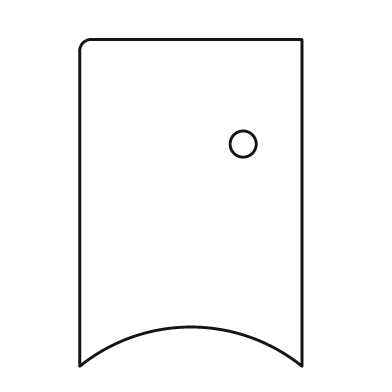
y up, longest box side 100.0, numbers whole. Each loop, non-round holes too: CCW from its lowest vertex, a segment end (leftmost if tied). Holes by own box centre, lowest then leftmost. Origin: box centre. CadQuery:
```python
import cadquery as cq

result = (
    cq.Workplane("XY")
    .moveTo(-34.0, -50.0)
    .threePointArc((0.0, -38.0), (34.0, -50.0))
    .lineTo(34.0, 50.0)
    .lineTo(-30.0, 50.0)
    .threePointArc((-33.0, 49.0), (-34.0, 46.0))
    .close()
    .moveTo(16.0, 18.0)
    .circle(4.0)
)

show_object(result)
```